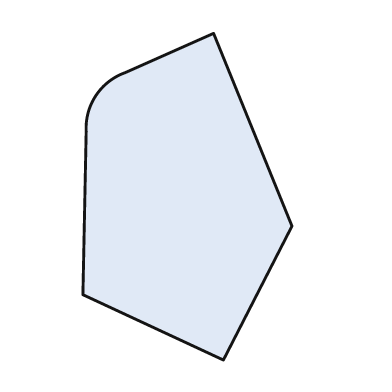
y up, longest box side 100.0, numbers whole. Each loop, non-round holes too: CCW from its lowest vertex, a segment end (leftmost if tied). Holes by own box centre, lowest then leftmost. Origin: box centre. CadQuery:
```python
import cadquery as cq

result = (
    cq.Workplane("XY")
    .moveTo(11.0, -50.0)
    .lineTo(32.0, -9.0)
    .lineTo(8.0, 50.0)
    .lineTo(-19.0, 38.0)
    .threePointArc((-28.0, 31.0), (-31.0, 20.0))
    .lineTo(-32.0, -30.0)
    .close()
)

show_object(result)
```